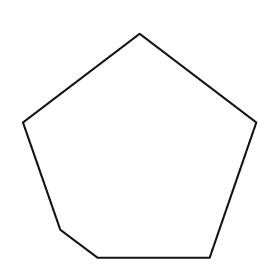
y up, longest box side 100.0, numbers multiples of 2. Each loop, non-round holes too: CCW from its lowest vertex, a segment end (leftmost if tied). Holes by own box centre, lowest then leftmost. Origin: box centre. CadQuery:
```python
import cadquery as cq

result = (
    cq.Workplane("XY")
    .moveTo(-18.0, -48.0)
    .lineTo(30.0, -48.0)
    .lineTo(50.0, 10.0)
    .lineTo(0.0, 48.0)
    .lineTo(-50.0, 10.0)
    .lineTo(-34.0, -36.0)
    .close()
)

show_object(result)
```